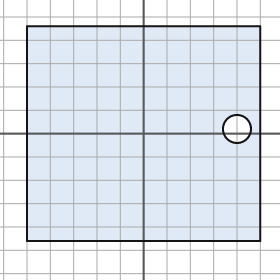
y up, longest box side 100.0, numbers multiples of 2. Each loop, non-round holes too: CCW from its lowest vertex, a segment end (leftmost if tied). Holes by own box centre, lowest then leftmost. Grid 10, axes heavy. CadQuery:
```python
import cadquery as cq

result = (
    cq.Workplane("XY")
    .moveTo(-50.0, -46.0)
    .lineTo(50.0, -46.0)
    .lineTo(50.0, 46.0)
    .lineTo(-50.0, 46.0)
    .close()
    .moveTo(40.0, 2.0)
    .circle(6.0)
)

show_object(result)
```